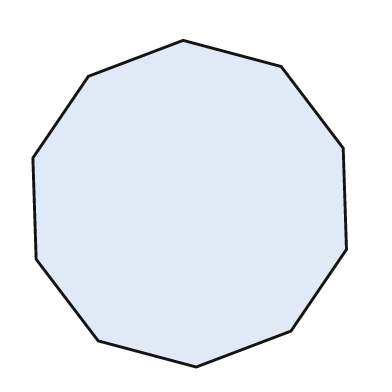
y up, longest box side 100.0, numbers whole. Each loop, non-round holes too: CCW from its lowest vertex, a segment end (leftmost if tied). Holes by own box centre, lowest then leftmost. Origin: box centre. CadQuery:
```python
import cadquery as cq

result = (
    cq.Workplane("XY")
    .moveTo(2.0, -50.0)
    .lineTo(31.0, -39.0)
    .lineTo(48.0, -14.0)
    .lineTo(47.0, 17.0)
    .lineTo(28.0, 42.0)
    .lineTo(-2.0, 50.0)
    .lineTo(-31.0, 39.0)
    .lineTo(-48.0, 14.0)
    .lineTo(-47.0, -17.0)
    .lineTo(-28.0, -42.0)
    .close()
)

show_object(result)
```